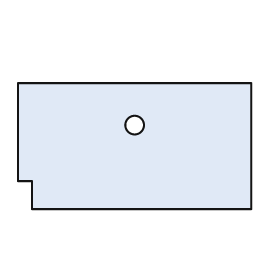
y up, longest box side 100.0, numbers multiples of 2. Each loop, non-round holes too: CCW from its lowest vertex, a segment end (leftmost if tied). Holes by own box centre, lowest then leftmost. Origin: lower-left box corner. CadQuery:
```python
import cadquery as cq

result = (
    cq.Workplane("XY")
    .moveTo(6.0, 0.0)
    .lineTo(100.0, 0.0)
    .lineTo(100.0, 54.0)
    .lineTo(0.0, 54.0)
    .lineTo(0.0, 12.0)
    .lineTo(6.0, 12.0)
    .close()
    .moveTo(50.0, 36.0)
    .circle(4.0)
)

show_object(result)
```